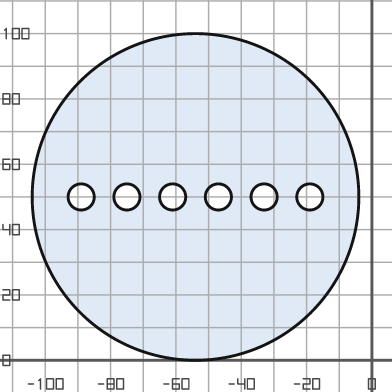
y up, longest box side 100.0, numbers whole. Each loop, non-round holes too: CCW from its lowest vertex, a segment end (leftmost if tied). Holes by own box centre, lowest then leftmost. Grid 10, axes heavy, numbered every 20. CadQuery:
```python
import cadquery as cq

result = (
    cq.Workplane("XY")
    .moveTo(-54.0, 50.0)
    .circle(50.0)
    .moveTo(-89.0, 50.0)
    .circle(4.0)
    .moveTo(-75.0, 50.0)
    .circle(4.0)
    .moveTo(-61.0, 50.0)
    .circle(4.0)
    .moveTo(-47.0, 50.0)
    .circle(4.0)
    .moveTo(-33.0, 50.0)
    .circle(4.0)
    .moveTo(-19.0, 50.0)
    .circle(4.0)
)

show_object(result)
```